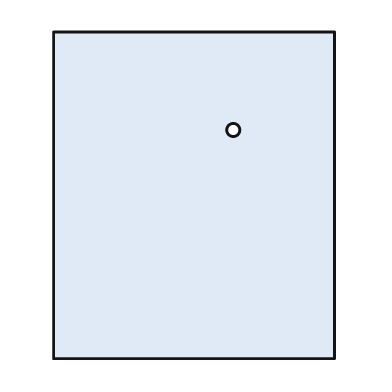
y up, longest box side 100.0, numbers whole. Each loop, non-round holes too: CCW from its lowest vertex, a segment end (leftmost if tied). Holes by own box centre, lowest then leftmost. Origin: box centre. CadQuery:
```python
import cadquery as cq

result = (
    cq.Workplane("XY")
    .moveTo(-43.0, -50.0)
    .lineTo(43.0, -50.0)
    .lineTo(43.0, 50.0)
    .lineTo(-43.0, 50.0)
    .close()
    .moveTo(12.0, 20.0)
    .circle(2.0)
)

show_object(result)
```